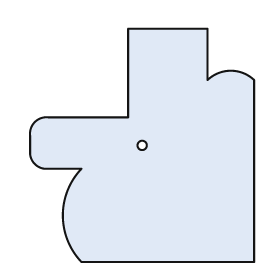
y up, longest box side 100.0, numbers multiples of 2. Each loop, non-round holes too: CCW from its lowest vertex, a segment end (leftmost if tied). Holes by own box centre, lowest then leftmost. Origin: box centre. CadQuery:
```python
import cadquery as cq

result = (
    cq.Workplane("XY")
    .moveTo(-26.0, -50.0)
    .lineTo(48.0, -50.0)
    .lineTo(48.0, 28.0)
    .threePointArc((38.0, 32.0), (28.0, 28.0))
    .lineTo(28.0, 50.0)
    .lineTo(-6.0, 50.0)
    .lineTo(-6.0, 12.0)
    .lineTo(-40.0, 12.0)
    .threePointArc((-46.0, 10.0), (-48.0, 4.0))
    .lineTo(-48.0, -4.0)
    .threePointArc((-46.0, -8.0), (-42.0, -10.0))
    .lineTo(-26.0, -10.0)
    .threePointArc((-34.0, -30.0), (-26.0, -50.0))
    .close()
    .moveTo(0.0, 0.0)
    .circle(2.0)
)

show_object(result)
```